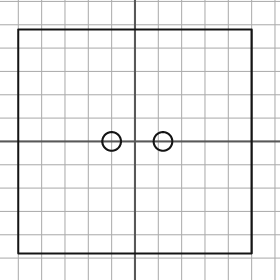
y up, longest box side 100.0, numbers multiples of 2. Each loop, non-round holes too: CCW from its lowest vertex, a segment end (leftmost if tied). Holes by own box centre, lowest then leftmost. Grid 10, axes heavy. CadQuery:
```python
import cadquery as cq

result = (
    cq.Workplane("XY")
    .moveTo(-50.0, -48.0)
    .lineTo(50.0, -48.0)
    .lineTo(50.0, 48.0)
    .lineTo(-50.0, 48.0)
    .close()
    .moveTo(-10.0, 0.0)
    .circle(4.0)
    .moveTo(12.0, 0.0)
    .circle(4.0)
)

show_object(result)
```